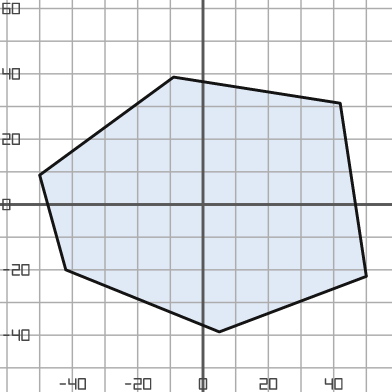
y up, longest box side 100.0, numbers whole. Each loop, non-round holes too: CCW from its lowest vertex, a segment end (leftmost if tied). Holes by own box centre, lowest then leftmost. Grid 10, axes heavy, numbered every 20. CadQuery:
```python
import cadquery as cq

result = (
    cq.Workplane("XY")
    .moveTo(5.0, -39.0)
    .lineTo(50.0, -22.0)
    .lineTo(42.0, 31.0)
    .lineTo(-9.0, 39.0)
    .lineTo(-50.0, 9.0)
    .lineTo(-42.0, -20.0)
    .close()
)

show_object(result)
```